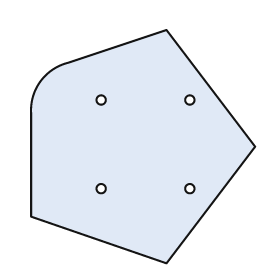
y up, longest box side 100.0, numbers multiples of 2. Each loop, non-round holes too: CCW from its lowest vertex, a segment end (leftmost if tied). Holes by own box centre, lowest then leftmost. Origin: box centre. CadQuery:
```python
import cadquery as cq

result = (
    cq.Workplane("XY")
    .moveTo(10.0, -50.0)
    .lineTo(48.0, 0.0)
    .lineTo(10.0, 50.0)
    .lineTo(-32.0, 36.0)
    .threePointArc((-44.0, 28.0), (-48.0, 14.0))
    .lineTo(-48.0, -30.0)
    .close()
    .moveTo(-18.0, -18.0)
    .circle(2.0)
    .moveTo(20.0, -18.0)
    .circle(2.0)
    .moveTo(-18.0, 20.0)
    .circle(2.0)
    .moveTo(20.0, 20.0)
    .circle(2.0)
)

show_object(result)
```